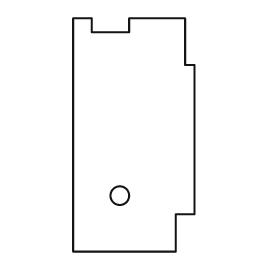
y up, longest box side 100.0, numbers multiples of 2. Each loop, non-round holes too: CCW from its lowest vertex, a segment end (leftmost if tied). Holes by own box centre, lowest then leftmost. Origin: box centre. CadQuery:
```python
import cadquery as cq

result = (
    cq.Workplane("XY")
    .moveTo(-26.0, -50.0)
    .lineTo(18.0, -50.0)
    .lineTo(18.0, -34.0)
    .lineTo(26.0, -34.0)
    .lineTo(26.0, 30.0)
    .lineTo(22.0, 30.0)
    .lineTo(22.0, 50.0)
    .lineTo(-2.0, 50.0)
    .lineTo(-2.0, 44.0)
    .lineTo(-18.0, 44.0)
    .lineTo(-18.0, 50.0)
    .lineTo(-26.0, 50.0)
    .close()
    .moveTo(-6.0, -26.0)
    .circle(4.0)
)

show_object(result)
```